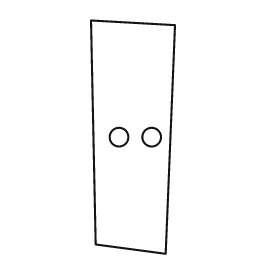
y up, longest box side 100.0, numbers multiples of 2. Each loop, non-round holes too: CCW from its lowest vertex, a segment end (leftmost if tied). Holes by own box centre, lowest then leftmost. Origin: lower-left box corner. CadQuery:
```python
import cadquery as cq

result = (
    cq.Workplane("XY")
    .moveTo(32.0, 0.0)
    .lineTo(36.0, 98.0)
    .lineTo(0.0, 100.0)
    .lineTo(2.0, 4.0)
    .close()
    .moveTo(12.0, 50.0)
    .circle(4.0)
    .moveTo(26.0, 50.0)
    .circle(4.0)
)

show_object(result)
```